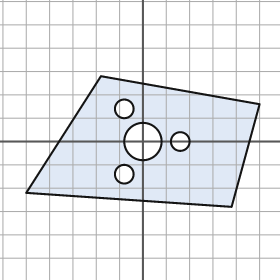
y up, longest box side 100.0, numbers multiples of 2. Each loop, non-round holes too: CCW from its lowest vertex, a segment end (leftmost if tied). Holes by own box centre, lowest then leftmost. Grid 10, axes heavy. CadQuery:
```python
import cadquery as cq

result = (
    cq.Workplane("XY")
    .moveTo(38.0, -28.0)
    .lineTo(50.0, 16.0)
    .lineTo(-18.0, 28.0)
    .lineTo(-50.0, -22.0)
    .close()
    .moveTo(-8.0, -14.0)
    .circle(4.0)
    .moveTo(0.0, 0.0)
    .circle(8.0)
    .moveTo(16.0, 0.0)
    .circle(4.0)
    .moveTo(-8.0, 14.0)
    .circle(4.0)
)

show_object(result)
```